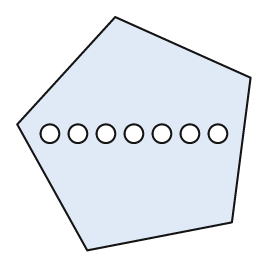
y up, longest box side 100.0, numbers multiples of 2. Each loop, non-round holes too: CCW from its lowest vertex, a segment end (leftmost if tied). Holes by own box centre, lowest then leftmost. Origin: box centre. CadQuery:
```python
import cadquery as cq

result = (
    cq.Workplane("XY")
    .moveTo(-20.0, -50.0)
    .lineTo(42.0, -38.0)
    .lineTo(50.0, 24.0)
    .lineTo(-8.0, 50.0)
    .lineTo(-50.0, 4.0)
    .close()
    .moveTo(-36.0, 0.0)
    .circle(4.0)
    .moveTo(-24.0, 0.0)
    .circle(4.0)
    .moveTo(-12.0, 0.0)
    .circle(4.0)
    .moveTo(0.0, 0.0)
    .circle(4.0)
    .moveTo(12.0, 0.0)
    .circle(4.0)
    .moveTo(24.0, 0.0)
    .circle(4.0)
    .moveTo(36.0, 0.0)
    .circle(4.0)
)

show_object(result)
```